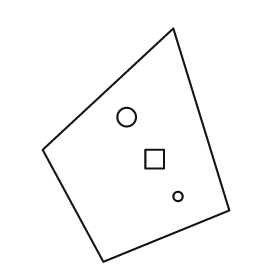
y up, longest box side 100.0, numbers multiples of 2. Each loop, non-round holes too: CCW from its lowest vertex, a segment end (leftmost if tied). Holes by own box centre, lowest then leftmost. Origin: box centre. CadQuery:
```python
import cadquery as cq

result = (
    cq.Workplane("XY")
    .moveTo(-14.0, -50.0)
    .lineTo(40.0, -28.0)
    .lineTo(16.0, 50.0)
    .lineTo(-40.0, -2.0)
    .close()
    .moveTo(18.0, -22.0)
    .circle(2.0)
    .moveTo(4.0, -10.0)
    .lineTo(12.0, -10.0)
    .lineTo(12.0, -2.0)
    .lineTo(4.0, -2.0)
    .close()
    .moveTo(-4.0, 12.0)
    .circle(4.0)
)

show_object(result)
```